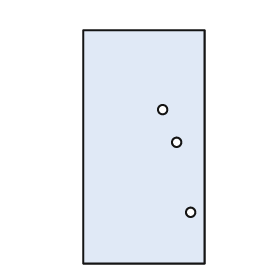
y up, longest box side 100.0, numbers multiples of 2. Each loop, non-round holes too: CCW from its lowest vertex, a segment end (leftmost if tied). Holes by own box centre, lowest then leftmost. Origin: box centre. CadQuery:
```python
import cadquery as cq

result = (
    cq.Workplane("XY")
    .moveTo(-26.0, -50.0)
    .lineTo(26.0, -50.0)
    .lineTo(26.0, 50.0)
    .lineTo(-26.0, 50.0)
    .close()
    .moveTo(20.0, -28.0)
    .circle(2.0)
    .moveTo(14.0, 2.0)
    .circle(2.0)
    .moveTo(8.0, 16.0)
    .circle(2.0)
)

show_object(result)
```